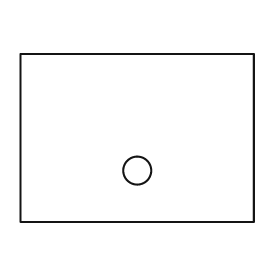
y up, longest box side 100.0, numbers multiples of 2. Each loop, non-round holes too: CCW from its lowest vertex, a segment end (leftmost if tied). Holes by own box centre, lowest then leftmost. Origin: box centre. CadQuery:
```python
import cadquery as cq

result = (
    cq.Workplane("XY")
    .moveTo(-50.0, -36.0)
    .lineTo(50.0, -36.0)
    .lineTo(50.0, 36.0)
    .lineTo(-50.0, 36.0)
    .close()
    .moveTo(0.0, -14.0)
    .circle(6.0)
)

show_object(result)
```